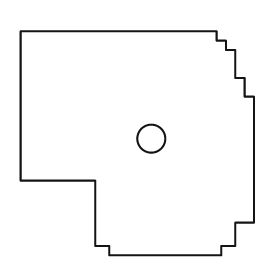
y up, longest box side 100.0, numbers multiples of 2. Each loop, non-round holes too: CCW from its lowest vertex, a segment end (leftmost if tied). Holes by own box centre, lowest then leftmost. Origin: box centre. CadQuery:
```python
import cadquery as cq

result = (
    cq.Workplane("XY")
    .moveTo(-12.0, -48.0)
    .lineTo(36.0, -48.0)
    .lineTo(36.0, -44.0)
    .lineTo(42.0, -44.0)
    .lineTo(42.0, -34.0)
    .lineTo(50.0, -34.0)
    .lineTo(50.0, 20.0)
    .lineTo(46.0, 20.0)
    .lineTo(46.0, 28.0)
    .lineTo(42.0, 28.0)
    .lineTo(42.0, 40.0)
    .lineTo(38.0, 40.0)
    .lineTo(38.0, 44.0)
    .lineTo(34.0, 44.0)
    .lineTo(34.0, 48.0)
    .lineTo(-50.0, 48.0)
    .lineTo(-50.0, -16.0)
    .lineTo(-18.0, -16.0)
    .lineTo(-18.0, -44.0)
    .lineTo(-12.0, -44.0)
    .close()
    .moveTo(6.0, 2.0)
    .circle(6.0)
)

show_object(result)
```